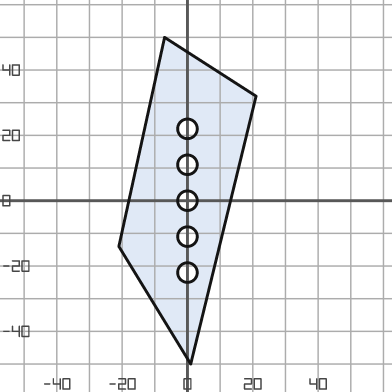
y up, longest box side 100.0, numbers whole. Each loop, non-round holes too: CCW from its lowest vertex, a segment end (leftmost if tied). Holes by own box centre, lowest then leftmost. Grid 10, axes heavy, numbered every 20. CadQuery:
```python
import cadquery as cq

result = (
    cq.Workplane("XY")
    .moveTo(1.0, -50.0)
    .lineTo(21.0, 32.0)
    .lineTo(-7.0, 50.0)
    .lineTo(-21.0, -14.0)
    .close()
    .moveTo(0.0, -22.0)
    .circle(3.0)
    .moveTo(0.0, -11.0)
    .circle(3.0)
    .moveTo(0.0, 0.0)
    .circle(3.0)
    .moveTo(0.0, 11.0)
    .circle(3.0)
    .moveTo(0.0, 22.0)
    .circle(3.0)
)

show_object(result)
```